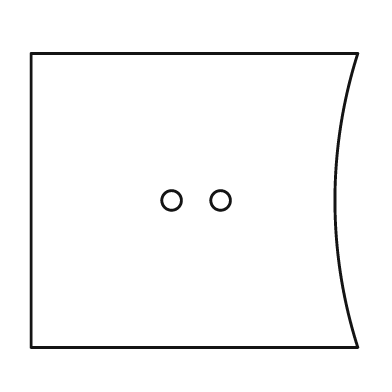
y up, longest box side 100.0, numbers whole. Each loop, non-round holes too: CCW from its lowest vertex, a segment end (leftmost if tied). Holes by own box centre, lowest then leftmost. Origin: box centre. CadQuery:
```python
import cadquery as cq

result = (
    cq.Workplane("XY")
    .moveTo(-50.0, -45.0)
    .lineTo(50.0, -45.0)
    .threePointArc((43.0, 0.0), (50.0, 45.0))
    .lineTo(-50.0, 45.0)
    .close()
    .moveTo(-7.0, 0.0)
    .circle(3.0)
    .moveTo(8.0, 0.0)
    .circle(3.0)
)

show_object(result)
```